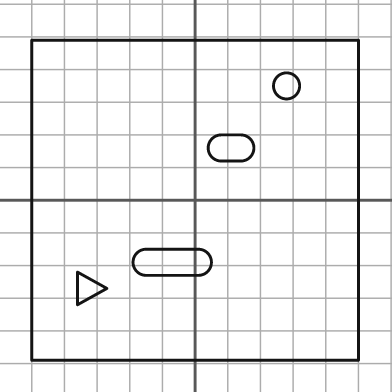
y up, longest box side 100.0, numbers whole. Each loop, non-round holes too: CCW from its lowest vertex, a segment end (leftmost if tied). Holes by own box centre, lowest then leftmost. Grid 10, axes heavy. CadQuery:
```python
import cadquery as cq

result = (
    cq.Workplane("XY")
    .moveTo(-50.0, -49.0)
    .lineTo(50.0, -49.0)
    .lineTo(50.0, 49.0)
    .lineTo(-50.0, 49.0)
    .close()
    .moveTo(-36.0, -32.0)
    .lineTo(-27.0, -27.0)
    .lineTo(-36.0, -22.0)
    .close()
    .moveTo(-15.0, -23.0)
    .lineTo(1.0, -23.0)
    .threePointArc((5.0, -19.0), (1.0, -15.0))
    .lineTo(-15.0, -15.0)
    .threePointArc((-19.0, -19.0), (-15.0, -23.0))
    .close()
    .moveTo(8.0, 12.0)
    .lineTo(14.0, 12.0)
    .threePointArc((18.0, 16.0), (14.0, 20.0))
    .lineTo(8.0, 20.0)
    .threePointArc((4.0, 16.0), (8.0, 12.0))
    .close()
    .moveTo(28.0, 35.0)
    .circle(4.0)
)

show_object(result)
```